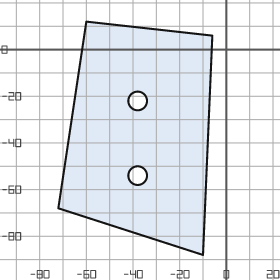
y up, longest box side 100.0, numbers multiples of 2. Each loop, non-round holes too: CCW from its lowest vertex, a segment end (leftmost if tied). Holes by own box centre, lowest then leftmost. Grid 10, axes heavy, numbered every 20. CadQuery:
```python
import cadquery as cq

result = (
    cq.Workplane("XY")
    .moveTo(-10.0, -88.0)
    .lineTo(-6.0, 6.0)
    .lineTo(-60.0, 12.0)
    .lineTo(-72.0, -68.0)
    .close()
    .moveTo(-38.0, -54.0)
    .circle(4.0)
    .moveTo(-38.0, -22.0)
    .circle(4.0)
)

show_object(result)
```